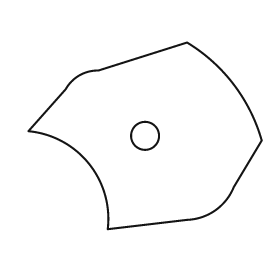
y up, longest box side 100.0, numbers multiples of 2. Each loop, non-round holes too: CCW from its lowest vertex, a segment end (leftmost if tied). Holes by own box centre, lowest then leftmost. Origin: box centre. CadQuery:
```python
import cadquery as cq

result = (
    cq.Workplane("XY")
    .moveTo(-16.0, -40.0)
    .lineTo(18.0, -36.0)
    .threePointArc((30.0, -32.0), (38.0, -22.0))
    .lineTo(50.0, -2.0)
    .threePointArc((38.0, 22.0), (18.0, 40.0))
    .lineTo(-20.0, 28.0)
    .threePointArc((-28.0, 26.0), (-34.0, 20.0))
    .lineTo(-50.0, 2.0)
    .threePointArc((-24.0, -12.0), (-16.0, -40.0))
    .close()
    .moveTo(0.0, 0.0)
    .circle(6.0)
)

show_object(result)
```